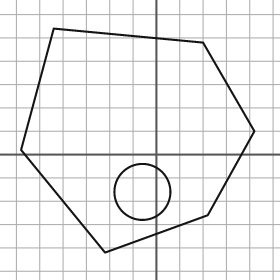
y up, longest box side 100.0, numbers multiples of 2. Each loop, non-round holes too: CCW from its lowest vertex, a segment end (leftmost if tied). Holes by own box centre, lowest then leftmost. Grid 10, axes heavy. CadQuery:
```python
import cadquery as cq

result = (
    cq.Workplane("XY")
    .moveTo(-22.0, -42.0)
    .lineTo(22.0, -26.0)
    .lineTo(42.0, 10.0)
    .lineTo(20.0, 48.0)
    .lineTo(-44.0, 54.0)
    .lineTo(-58.0, 2.0)
    .close()
    .moveTo(-6.0, -16.0)
    .circle(12.0)
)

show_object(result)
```